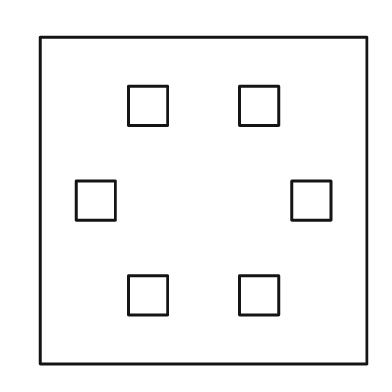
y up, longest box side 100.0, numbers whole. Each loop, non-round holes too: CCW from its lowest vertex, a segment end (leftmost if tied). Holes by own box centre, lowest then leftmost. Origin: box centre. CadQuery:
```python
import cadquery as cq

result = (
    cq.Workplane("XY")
    .moveTo(-50.0, -50.0)
    .lineTo(50.0, -50.0)
    .lineTo(50.0, 50.0)
    .lineTo(-50.0, 50.0)
    .close()
    .moveTo(-23.0, -35.0)
    .lineTo(-11.0, -35.0)
    .lineTo(-11.0, -23.0)
    .lineTo(-23.0, -23.0)
    .close()
    .moveTo(11.0, -35.0)
    .lineTo(23.0, -35.0)
    .lineTo(23.0, -23.0)
    .lineTo(11.0, -23.0)
    .close()
    .moveTo(-39.0, -6.0)
    .lineTo(-27.0, -6.0)
    .lineTo(-27.0, 6.0)
    .lineTo(-39.0, 6.0)
    .close()
    .moveTo(27.0, -6.0)
    .lineTo(39.0, -6.0)
    .lineTo(39.0, 6.0)
    .lineTo(27.0, 6.0)
    .close()
    .moveTo(-23.0, 23.0)
    .lineTo(-11.0, 23.0)
    .lineTo(-11.0, 35.0)
    .lineTo(-23.0, 35.0)
    .close()
    .moveTo(11.0, 23.0)
    .lineTo(23.0, 23.0)
    .lineTo(23.0, 35.0)
    .lineTo(11.0, 35.0)
    .close()
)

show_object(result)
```